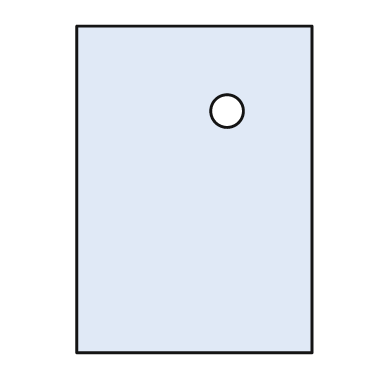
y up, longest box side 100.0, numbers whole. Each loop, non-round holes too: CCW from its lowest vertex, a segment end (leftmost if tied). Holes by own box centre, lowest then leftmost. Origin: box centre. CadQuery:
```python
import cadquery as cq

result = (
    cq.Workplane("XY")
    .moveTo(-36.0, -50.0)
    .lineTo(36.0, -50.0)
    .lineTo(36.0, 50.0)
    .lineTo(-36.0, 50.0)
    .close()
    .moveTo(10.0, 24.0)
    .circle(5.0)
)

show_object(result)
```